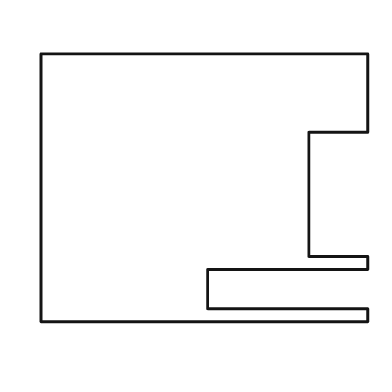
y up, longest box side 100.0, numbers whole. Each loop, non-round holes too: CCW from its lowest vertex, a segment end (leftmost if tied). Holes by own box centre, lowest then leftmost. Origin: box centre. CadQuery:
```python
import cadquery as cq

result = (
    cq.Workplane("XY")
    .moveTo(-50.0, -41.0)
    .lineTo(50.0, -41.0)
    .lineTo(50.0, -37.0)
    .lineTo(1.0, -37.0)
    .lineTo(1.0, -25.0)
    .lineTo(50.0, -25.0)
    .lineTo(50.0, -21.0)
    .lineTo(32.0, -21.0)
    .lineTo(32.0, 17.0)
    .lineTo(50.0, 17.0)
    .lineTo(50.0, 41.0)
    .lineTo(-50.0, 41.0)
    .close()
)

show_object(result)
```